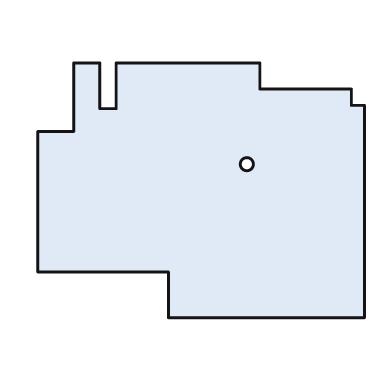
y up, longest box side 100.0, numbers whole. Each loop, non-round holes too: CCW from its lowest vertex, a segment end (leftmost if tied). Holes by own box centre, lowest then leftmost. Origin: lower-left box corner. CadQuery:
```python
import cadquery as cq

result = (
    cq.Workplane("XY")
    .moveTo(40.0, 0.0)
    .lineTo(100.0, 0.0)
    .lineTo(100.0, 65.0)
    .lineTo(96.0, 65.0)
    .lineTo(96.0, 70.0)
    .lineTo(68.0, 70.0)
    .lineTo(68.0, 78.0)
    .lineTo(24.0, 78.0)
    .lineTo(24.0, 64.0)
    .lineTo(19.0, 64.0)
    .lineTo(19.0, 78.0)
    .lineTo(11.0, 78.0)
    .lineTo(11.0, 57.0)
    .lineTo(0.0, 57.0)
    .lineTo(0.0, 14.0)
    .lineTo(40.0, 14.0)
    .close()
    .moveTo(64.0, 47.0)
    .circle(2.0)
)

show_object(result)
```